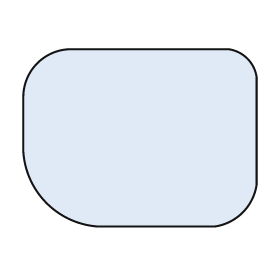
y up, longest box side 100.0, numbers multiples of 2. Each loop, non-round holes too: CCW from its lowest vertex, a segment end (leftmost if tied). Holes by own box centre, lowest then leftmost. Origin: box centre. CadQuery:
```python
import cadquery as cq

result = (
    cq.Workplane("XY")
    .moveTo(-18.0, -38.0)
    .lineTo(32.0, -38.0)
    .threePointArc((44.0, -32.0), (50.0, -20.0))
    .lineTo(50.0, 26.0)
    .threePointArc((46.0, 34.0), (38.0, 38.0))
    .lineTo(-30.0, 38.0)
    .threePointArc((-44.0, 32.0), (-50.0, 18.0))
    .lineTo(-50.0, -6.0)
    .threePointArc((-40.0, -28.0), (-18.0, -38.0))
    .close()
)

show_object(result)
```